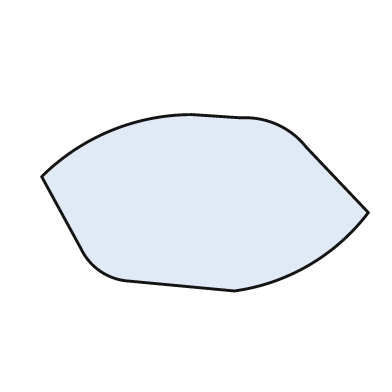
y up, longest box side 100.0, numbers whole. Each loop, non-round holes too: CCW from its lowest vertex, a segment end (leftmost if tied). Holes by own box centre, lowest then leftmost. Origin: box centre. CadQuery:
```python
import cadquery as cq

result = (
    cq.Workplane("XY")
    .moveTo(9.0, -27.0)
    .threePointArc((32.0, -19.0), (50.0, -3.0))
    .lineTo(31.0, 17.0)
    .threePointArc((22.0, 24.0), (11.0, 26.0))
    .lineTo(-4.0, 27.0)
    .threePointArc((-29.0, 22.0), (-50.0, 8.0))
    .lineTo(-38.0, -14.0)
    .threePointArc((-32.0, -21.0), (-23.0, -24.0))
    .close()
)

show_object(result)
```